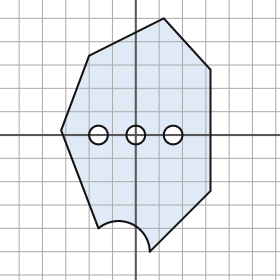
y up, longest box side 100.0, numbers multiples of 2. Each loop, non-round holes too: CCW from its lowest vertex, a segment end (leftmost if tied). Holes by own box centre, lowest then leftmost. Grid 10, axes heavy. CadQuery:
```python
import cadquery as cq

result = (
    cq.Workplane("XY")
    .moveTo(6.0, -50.0)
    .lineTo(32.0, -24.0)
    .lineTo(32.0, 28.0)
    .lineTo(12.0, 50.0)
    .lineTo(-20.0, 34.0)
    .lineTo(-32.0, 2.0)
    .lineTo(-16.0, -40.0)
    .threePointArc((-2.0, -38.0), (6.0, -50.0))
    .close()
    .moveTo(-16.0, 0.0)
    .circle(4.0)
    .moveTo(0.0, 0.0)
    .circle(4.0)
    .moveTo(16.0, 0.0)
    .circle(4.0)
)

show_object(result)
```